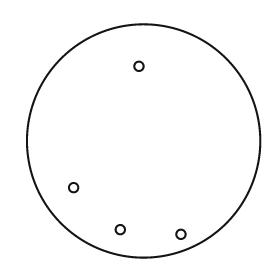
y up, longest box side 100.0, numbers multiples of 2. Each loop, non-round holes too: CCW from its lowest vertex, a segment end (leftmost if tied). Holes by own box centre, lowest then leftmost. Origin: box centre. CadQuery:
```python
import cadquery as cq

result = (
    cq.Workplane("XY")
    .moveTo(0.0, 0.0)
    .circle(50.0)
    .moveTo(16.0, -40.0)
    .circle(2.0)
    .moveTo(-10.0, -38.0)
    .circle(2.0)
    .moveTo(-30.0, -20.0)
    .circle(2.0)
    .moveTo(-2.0, 32.0)
    .circle(2.0)
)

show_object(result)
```